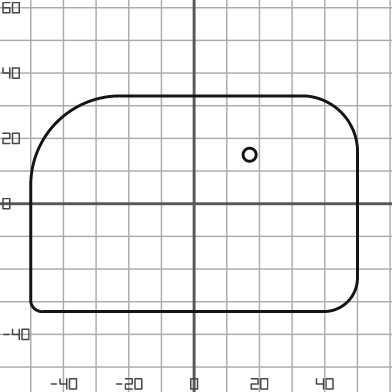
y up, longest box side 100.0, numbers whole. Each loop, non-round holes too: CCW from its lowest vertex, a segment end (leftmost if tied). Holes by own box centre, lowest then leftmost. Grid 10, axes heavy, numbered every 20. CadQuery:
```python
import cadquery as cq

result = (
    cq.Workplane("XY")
    .moveTo(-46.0, -33.0)
    .lineTo(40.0, -33.0)
    .threePointArc((47.0, -30.0), (50.0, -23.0))
    .lineTo(50.0, 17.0)
    .threePointArc((45.0, 28.0), (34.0, 33.0))
    .lineTo(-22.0, 33.0)
    .threePointArc((-42.0, 25.0), (-50.0, 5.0))
    .lineTo(-50.0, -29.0)
    .threePointArc((-49.0, -32.0), (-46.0, -33.0))
    .close()
    .moveTo(17.0, 15.0)
    .circle(2.0)
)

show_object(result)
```